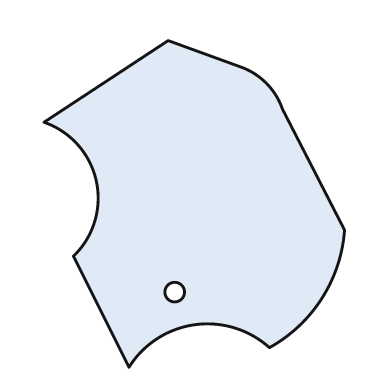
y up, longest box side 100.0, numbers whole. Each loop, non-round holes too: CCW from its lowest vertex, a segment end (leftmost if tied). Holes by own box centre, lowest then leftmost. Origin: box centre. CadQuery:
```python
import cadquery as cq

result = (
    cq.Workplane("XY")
    .moveTo(-20.0, -50.0)
    .threePointArc((0.0, -37.0), (23.0, -44.0))
    .threePointArc((39.0, -29.0), (46.0, -8.0))
    .lineTo(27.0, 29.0)
    .threePointArc((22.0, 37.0), (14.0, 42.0))
    .lineTo(-8.0, 50.0)
    .lineTo(-46.0, 25.0)
    .threePointArc((-30.0, 7.0), (-37.0, -16.0))
    .close()
    .moveTo(-6.0, -27.0)
    .circle(3.0)
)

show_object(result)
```